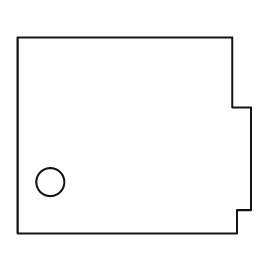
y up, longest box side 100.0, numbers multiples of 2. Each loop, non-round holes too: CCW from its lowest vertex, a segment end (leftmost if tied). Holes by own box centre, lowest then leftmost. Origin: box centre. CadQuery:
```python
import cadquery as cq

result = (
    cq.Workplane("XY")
    .moveTo(-50.0, -42.0)
    .lineTo(44.0, -42.0)
    .lineTo(44.0, -32.0)
    .lineTo(50.0, -32.0)
    .lineTo(50.0, 12.0)
    .lineTo(42.0, 12.0)
    .lineTo(42.0, 42.0)
    .lineTo(-50.0, 42.0)
    .close()
    .moveTo(-36.0, -20.0)
    .circle(6.0)
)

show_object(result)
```